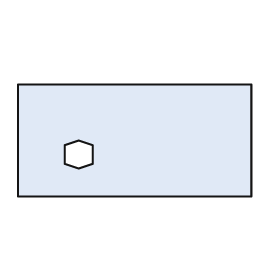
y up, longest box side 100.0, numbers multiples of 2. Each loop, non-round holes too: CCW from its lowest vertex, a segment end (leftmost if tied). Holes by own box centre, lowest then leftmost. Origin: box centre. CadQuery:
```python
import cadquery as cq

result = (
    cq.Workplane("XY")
    .moveTo(-50.0, -24.0)
    .lineTo(50.0, -24.0)
    .lineTo(50.0, 24.0)
    .lineTo(-50.0, 24.0)
    .close()
    .moveTo(-24.0, -12.0)
    .lineTo(-18.0, -10.0)
    .lineTo(-18.0, -2.0)
    .lineTo(-24.0, 0.0)
    .lineTo(-30.0, -2.0)
    .lineTo(-30.0, -10.0)
    .close()
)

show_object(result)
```